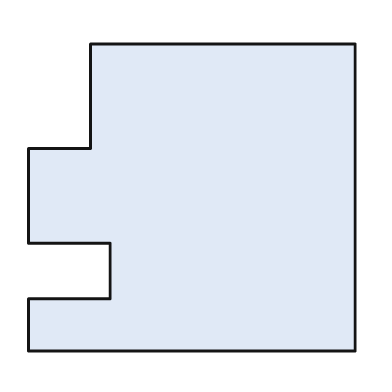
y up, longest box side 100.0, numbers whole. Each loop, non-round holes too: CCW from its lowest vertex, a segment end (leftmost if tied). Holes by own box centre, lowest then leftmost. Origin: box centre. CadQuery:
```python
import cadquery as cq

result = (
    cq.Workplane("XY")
    .moveTo(-50.0, -47.0)
    .lineTo(50.0, -47.0)
    .lineTo(50.0, 47.0)
    .lineTo(-31.0, 47.0)
    .lineTo(-31.0, 15.0)
    .lineTo(-50.0, 15.0)
    .lineTo(-50.0, -14.0)
    .lineTo(-25.0, -14.0)
    .lineTo(-25.0, -31.0)
    .lineTo(-50.0, -31.0)
    .close()
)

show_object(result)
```